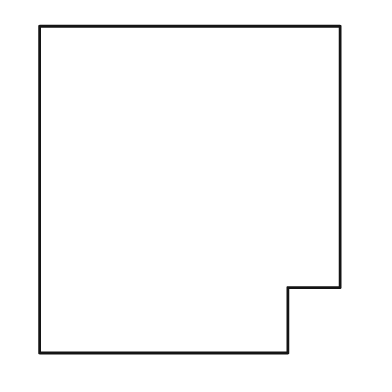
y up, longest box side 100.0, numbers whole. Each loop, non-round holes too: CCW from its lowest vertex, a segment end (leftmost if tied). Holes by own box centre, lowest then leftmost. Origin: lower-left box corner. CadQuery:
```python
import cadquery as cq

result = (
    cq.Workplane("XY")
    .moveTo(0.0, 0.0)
    .lineTo(76.0, 0.0)
    .lineTo(76.0, 20.0)
    .lineTo(92.0, 20.0)
    .lineTo(92.0, 100.0)
    .lineTo(0.0, 100.0)
    .close()
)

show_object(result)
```